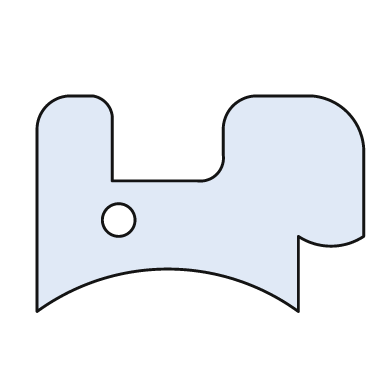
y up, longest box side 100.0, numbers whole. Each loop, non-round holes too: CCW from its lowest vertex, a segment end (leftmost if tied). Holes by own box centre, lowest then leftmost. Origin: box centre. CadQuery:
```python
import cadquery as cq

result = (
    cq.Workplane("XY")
    .moveTo(-50.0, -33.0)
    .threePointArc((-10.0, -20.0), (30.0, -33.0))
    .lineTo(30.0, -10.0)
    .threePointArc((40.0, -13.0), (50.0, -10.0))
    .lineTo(50.0, 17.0)
    .threePointArc((45.0, 28.0), (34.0, 33.0))
    .lineTo(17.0, 33.0)
    .threePointArc((10.0, 30.0), (7.0, 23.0))
    .lineTo(7.0, 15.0)
    .threePointArc((5.0, 9.0), (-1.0, 7.0))
    .lineTo(-27.0, 7.0)
    .lineTo(-27.0, 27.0)
    .threePointArc((-29.0, 31.0), (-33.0, 33.0))
    .lineTo(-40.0, 33.0)
    .threePointArc((-47.0, 30.0), (-50.0, 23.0))
    .close()
    .moveTo(-25.0, -5.0)
    .circle(5.0)
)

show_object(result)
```